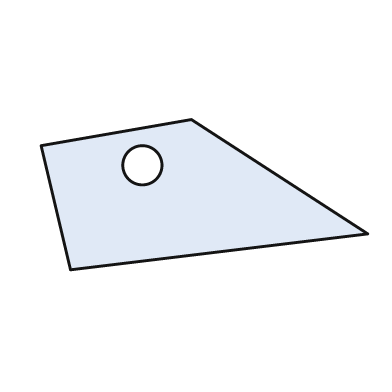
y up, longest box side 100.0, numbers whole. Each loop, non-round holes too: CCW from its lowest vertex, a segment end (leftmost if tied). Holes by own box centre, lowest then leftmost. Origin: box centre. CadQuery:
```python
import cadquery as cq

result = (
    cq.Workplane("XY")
    .moveTo(-41.0, -23.0)
    .lineTo(50.0, -12.0)
    .lineTo(-4.0, 23.0)
    .lineTo(-50.0, 15.0)
    .close()
    .moveTo(-19.0, 9.0)
    .circle(6.0)
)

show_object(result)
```